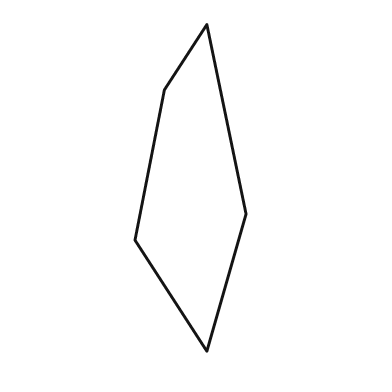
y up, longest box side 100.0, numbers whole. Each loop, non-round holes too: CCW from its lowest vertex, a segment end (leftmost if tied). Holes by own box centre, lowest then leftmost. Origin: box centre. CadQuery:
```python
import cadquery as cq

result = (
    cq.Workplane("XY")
    .moveTo(5.0, -50.0)
    .lineTo(17.0, -8.0)
    .lineTo(5.0, 50.0)
    .lineTo(-8.0, 30.0)
    .lineTo(-17.0, -16.0)
    .close()
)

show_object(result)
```